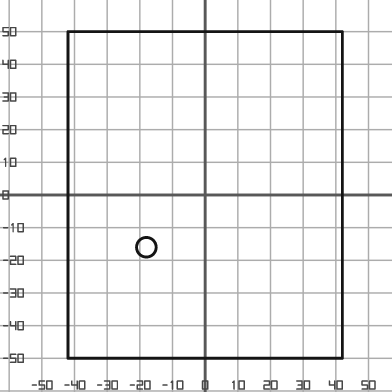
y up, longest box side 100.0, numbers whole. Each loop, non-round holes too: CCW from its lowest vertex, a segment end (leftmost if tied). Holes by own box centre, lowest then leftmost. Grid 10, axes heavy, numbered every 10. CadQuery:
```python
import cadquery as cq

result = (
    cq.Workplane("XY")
    .moveTo(-42.0, -50.0)
    .lineTo(42.0, -50.0)
    .lineTo(42.0, 50.0)
    .lineTo(-42.0, 50.0)
    .close()
    .moveTo(-18.0, -16.0)
    .circle(3.0)
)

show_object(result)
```